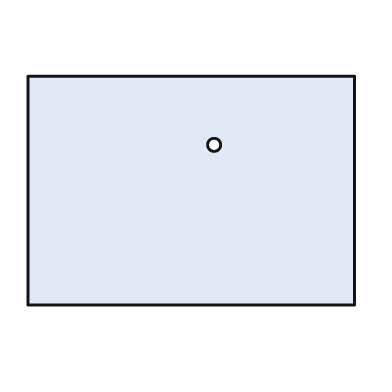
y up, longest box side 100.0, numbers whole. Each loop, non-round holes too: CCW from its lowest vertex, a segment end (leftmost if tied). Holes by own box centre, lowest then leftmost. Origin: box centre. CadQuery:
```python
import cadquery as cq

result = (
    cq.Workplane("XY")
    .moveTo(-50.0, -35.0)
    .lineTo(50.0, -35.0)
    .lineTo(50.0, 35.0)
    .lineTo(-50.0, 35.0)
    .close()
    .moveTo(7.0, 14.0)
    .circle(2.0)
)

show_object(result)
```